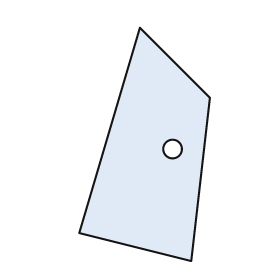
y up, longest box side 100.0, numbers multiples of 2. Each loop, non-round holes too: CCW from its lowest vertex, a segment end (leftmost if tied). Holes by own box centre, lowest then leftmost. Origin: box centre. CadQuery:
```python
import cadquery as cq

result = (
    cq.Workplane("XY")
    .moveTo(20.0, -50.0)
    .lineTo(28.0, 20.0)
    .lineTo(-2.0, 50.0)
    .lineTo(-28.0, -38.0)
    .close()
    .moveTo(12.0, -2.0)
    .circle(4.0)
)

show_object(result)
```